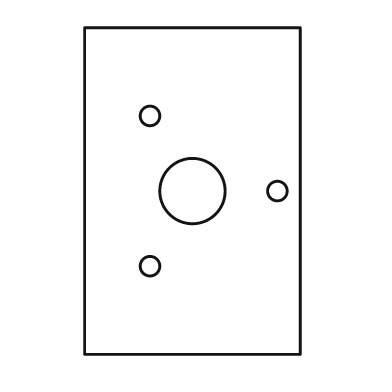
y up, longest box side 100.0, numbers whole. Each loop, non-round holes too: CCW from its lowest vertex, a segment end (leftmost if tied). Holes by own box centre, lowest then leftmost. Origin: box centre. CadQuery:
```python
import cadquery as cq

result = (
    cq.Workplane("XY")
    .moveTo(-33.0, -50.0)
    .lineTo(33.0, -50.0)
    .lineTo(33.0, 50.0)
    .lineTo(-33.0, 50.0)
    .close()
    .moveTo(-13.0, -23.0)
    .circle(3.0)
    .moveTo(0.0, 0.0)
    .circle(10.0)
    .moveTo(26.0, 0.0)
    .circle(3.0)
    .moveTo(-13.0, 23.0)
    .circle(3.0)
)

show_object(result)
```